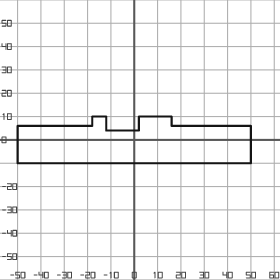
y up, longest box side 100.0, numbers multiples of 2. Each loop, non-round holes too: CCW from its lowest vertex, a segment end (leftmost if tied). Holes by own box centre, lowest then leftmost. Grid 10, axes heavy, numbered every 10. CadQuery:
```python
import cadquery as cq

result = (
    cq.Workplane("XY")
    .moveTo(-50.0, -10.0)
    .lineTo(50.0, -10.0)
    .lineTo(50.0, 6.0)
    .lineTo(16.0, 6.0)
    .lineTo(16.0, 10.0)
    .lineTo(2.0, 10.0)
    .lineTo(2.0, 4.0)
    .lineTo(-12.0, 4.0)
    .lineTo(-12.0, 10.0)
    .lineTo(-18.0, 10.0)
    .lineTo(-18.0, 6.0)
    .lineTo(-50.0, 6.0)
    .close()
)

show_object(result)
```